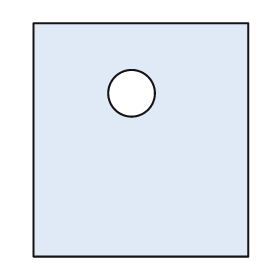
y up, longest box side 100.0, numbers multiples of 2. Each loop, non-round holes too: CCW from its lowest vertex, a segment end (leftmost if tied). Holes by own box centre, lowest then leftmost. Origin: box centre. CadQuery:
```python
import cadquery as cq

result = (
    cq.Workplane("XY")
    .moveTo(-46.0, -50.0)
    .lineTo(46.0, -50.0)
    .lineTo(46.0, 50.0)
    .lineTo(-46.0, 50.0)
    .close()
    .moveTo(-4.0, 20.0)
    .circle(10.0)
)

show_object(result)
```